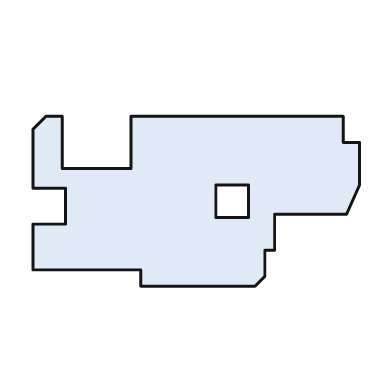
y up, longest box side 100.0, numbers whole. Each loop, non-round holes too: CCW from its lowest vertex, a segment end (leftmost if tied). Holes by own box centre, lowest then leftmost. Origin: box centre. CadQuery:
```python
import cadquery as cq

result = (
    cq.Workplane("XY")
    .moveTo(-17.0, -26.0)
    .lineTo(18.0, -26.0)
    .lineTo(21.0, -23.0)
    .lineTo(21.0, -15.0)
    .lineTo(24.0, -15.0)
    .lineTo(24.0, -4.0)
    .lineTo(46.0, -4.0)
    .lineTo(50.0, 5.0)
    .lineTo(50.0, 18.0)
    .lineTo(45.0, 18.0)
    .lineTo(45.0, 26.0)
    .lineTo(-20.0, 26.0)
    .lineTo(-20.0, 10.0)
    .lineTo(-41.0, 10.0)
    .lineTo(-41.0, 26.0)
    .lineTo(-46.0, 26.0)
    .lineTo(-50.0, 22.0)
    .lineTo(-50.0, 4.0)
    .lineTo(-40.0, 4.0)
    .lineTo(-40.0, -7.0)
    .lineTo(-50.0, -7.0)
    .lineTo(-50.0, -21.0)
    .lineTo(-17.0, -21.0)
    .close()
    .moveTo(6.0, -5.0)
    .lineTo(16.0, -5.0)
    .lineTo(16.0, 5.0)
    .lineTo(6.0, 5.0)
    .close()
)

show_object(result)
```